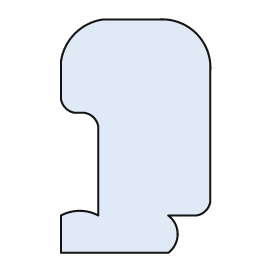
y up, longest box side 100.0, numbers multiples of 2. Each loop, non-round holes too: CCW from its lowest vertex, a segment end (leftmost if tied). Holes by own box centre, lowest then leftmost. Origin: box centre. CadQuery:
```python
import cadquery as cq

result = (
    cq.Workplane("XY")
    .moveTo(-32.0, -50.0)
    .lineTo(14.0, -50.0)
    .threePointArc((18.0, -42.0), (14.0, -34.0))
    .lineTo(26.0, -34.0)
    .threePointArc((30.0, -32.0), (32.0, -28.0))
    .lineTo(32.0, 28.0)
    .threePointArc((26.0, 44.0), (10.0, 50.0))
    .lineTo(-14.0, 50.0)
    .threePointArc((-26.0, 44.0), (-32.0, 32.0))
    .lineTo(-32.0, 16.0)
    .threePointArc((-30.0, 12.0), (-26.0, 10.0))
    .lineTo(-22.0, 10.0)
    .threePointArc((-18.0, 8.0), (-16.0, 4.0))
    .lineTo(-16.0, -34.0)
    .threePointArc((-24.0, -32.0), (-32.0, -34.0))
    .close()
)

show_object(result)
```